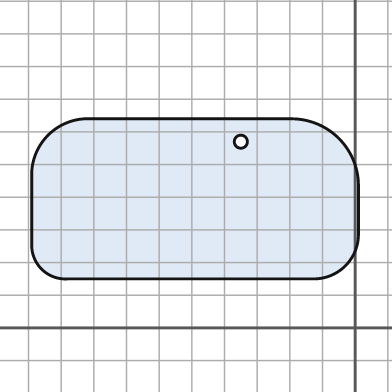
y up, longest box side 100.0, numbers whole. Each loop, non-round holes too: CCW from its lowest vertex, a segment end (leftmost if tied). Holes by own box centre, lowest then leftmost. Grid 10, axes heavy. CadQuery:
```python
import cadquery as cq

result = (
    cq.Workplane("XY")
    .moveTo(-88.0, 15.0)
    .lineTo(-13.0, 15.0)
    .threePointArc((-3.0, 19.0), (1.0, 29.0))
    .lineTo(1.0, 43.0)
    .threePointArc((-5.0, 58.0), (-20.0, 64.0))
    .lineTo(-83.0, 64.0)
    .threePointArc((-94.0, 59.0), (-99.0, 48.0))
    .lineTo(-99.0, 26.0)
    .threePointArc((-96.0, 18.0), (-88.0, 15.0))
    .close()
    .moveTo(-35.0, 57.0)
    .circle(2.0)
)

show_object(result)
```